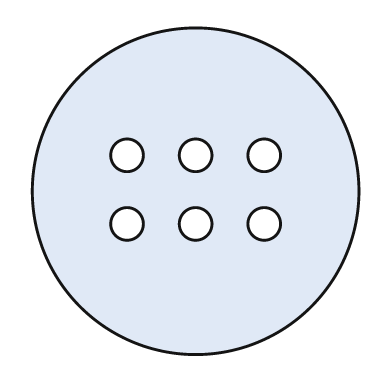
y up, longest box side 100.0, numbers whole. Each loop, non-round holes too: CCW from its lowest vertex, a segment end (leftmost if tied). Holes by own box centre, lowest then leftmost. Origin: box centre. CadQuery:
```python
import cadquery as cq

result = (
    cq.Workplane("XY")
    .moveTo(0.0, 0.0)
    .circle(50.0)
    .moveTo(-21.0, -10.0)
    .circle(5.0)
    .moveTo(0.0, -10.0)
    .circle(5.0)
    .moveTo(21.0, -10.0)
    .circle(5.0)
    .moveTo(-21.0, 11.0)
    .circle(5.0)
    .moveTo(0.0, 11.0)
    .circle(5.0)
    .moveTo(21.0, 11.0)
    .circle(5.0)
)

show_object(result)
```